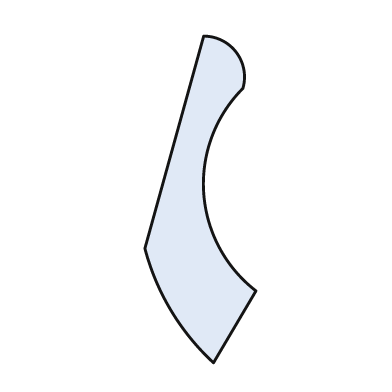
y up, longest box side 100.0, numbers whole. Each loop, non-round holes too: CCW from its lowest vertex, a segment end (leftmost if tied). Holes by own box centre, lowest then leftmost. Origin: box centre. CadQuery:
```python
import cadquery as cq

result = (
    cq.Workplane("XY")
    .moveTo(4.0, -50.0)
    .lineTo(17.0, -28.0)
    .threePointArc((1.0, 2.0), (13.0, 34.0))
    .threePointArc((11.0, 45.0), (1.0, 50.0))
    .lineTo(-17.0, -15.0)
    .threePointArc((-9.0, -34.0), (4.0, -50.0))
    .close()
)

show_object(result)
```